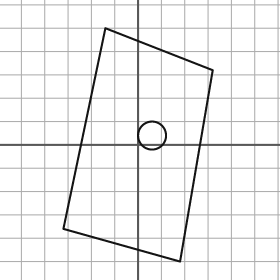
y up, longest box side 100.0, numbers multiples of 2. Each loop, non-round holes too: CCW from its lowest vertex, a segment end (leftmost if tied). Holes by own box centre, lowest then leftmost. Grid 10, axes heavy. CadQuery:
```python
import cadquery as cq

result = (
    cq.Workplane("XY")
    .moveTo(18.0, -50.0)
    .lineTo(32.0, 32.0)
    .lineTo(-14.0, 50.0)
    .lineTo(-32.0, -36.0)
    .close()
    .moveTo(6.0, 4.0)
    .circle(6.0)
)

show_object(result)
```